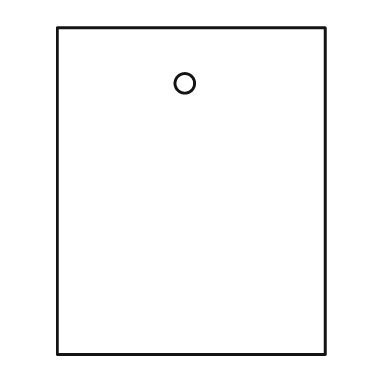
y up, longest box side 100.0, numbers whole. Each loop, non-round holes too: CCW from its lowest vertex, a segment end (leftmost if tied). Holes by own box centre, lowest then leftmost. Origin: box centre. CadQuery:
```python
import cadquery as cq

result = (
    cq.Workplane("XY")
    .moveTo(-41.0, -50.0)
    .lineTo(41.0, -50.0)
    .lineTo(41.0, 50.0)
    .lineTo(-41.0, 50.0)
    .close()
    .moveTo(-2.0, 33.0)
    .circle(3.0)
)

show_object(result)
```